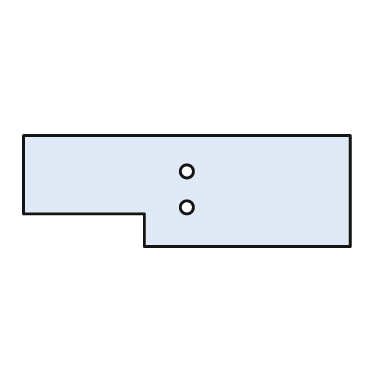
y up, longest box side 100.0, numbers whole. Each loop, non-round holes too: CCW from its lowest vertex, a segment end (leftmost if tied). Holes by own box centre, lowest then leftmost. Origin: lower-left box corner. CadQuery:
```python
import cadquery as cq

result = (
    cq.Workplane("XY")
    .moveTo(37.0, 0.0)
    .lineTo(100.0, 0.0)
    .lineTo(100.0, 34.0)
    .lineTo(0.0, 34.0)
    .lineTo(0.0, 10.0)
    .lineTo(37.0, 10.0)
    .close()
    .moveTo(50.0, 12.0)
    .circle(2.0)
    .moveTo(50.0, 23.0)
    .circle(2.0)
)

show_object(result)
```